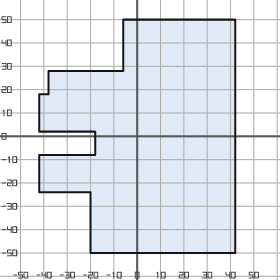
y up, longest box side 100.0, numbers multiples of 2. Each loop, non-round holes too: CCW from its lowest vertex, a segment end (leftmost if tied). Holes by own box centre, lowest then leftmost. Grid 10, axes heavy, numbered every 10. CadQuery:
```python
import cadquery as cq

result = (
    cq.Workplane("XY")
    .moveTo(-20.0, -50.0)
    .lineTo(42.0, -50.0)
    .lineTo(42.0, 50.0)
    .lineTo(-6.0, 50.0)
    .lineTo(-6.0, 28.0)
    .lineTo(-38.0, 28.0)
    .lineTo(-38.0, 18.0)
    .lineTo(-42.0, 18.0)
    .lineTo(-42.0, 2.0)
    .lineTo(-18.0, 2.0)
    .lineTo(-18.0, -8.0)
    .lineTo(-42.0, -8.0)
    .lineTo(-42.0, -24.0)
    .lineTo(-20.0, -24.0)
    .close()
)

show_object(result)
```